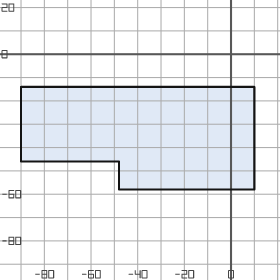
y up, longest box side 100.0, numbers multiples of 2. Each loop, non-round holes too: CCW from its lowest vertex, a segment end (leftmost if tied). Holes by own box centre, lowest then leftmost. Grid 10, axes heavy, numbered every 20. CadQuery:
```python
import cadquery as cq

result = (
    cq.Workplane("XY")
    .moveTo(-48.0, -58.0)
    .lineTo(10.0, -58.0)
    .lineTo(10.0, -14.0)
    .lineTo(-90.0, -14.0)
    .lineTo(-90.0, -46.0)
    .lineTo(-48.0, -46.0)
    .close()
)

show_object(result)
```